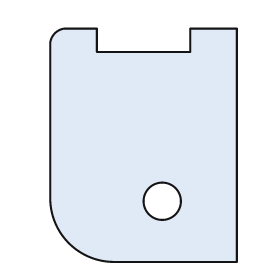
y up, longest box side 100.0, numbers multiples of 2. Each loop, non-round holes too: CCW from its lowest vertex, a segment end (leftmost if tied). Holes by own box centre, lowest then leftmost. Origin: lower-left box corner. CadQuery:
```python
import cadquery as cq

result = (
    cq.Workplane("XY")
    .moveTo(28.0, 0.0)
    .lineTo(80.0, 0.0)
    .lineTo(80.0, 100.0)
    .lineTo(60.0, 100.0)
    .lineTo(60.0, 90.0)
    .lineTo(20.0, 90.0)
    .lineTo(20.0, 100.0)
    .lineTo(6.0, 100.0)
    .threePointArc((2.0, 98.0), (0.0, 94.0))
    .lineTo(0.0, 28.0)
    .threePointArc((8.0, 8.0), (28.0, 0.0))
    .close()
    .moveTo(48.0, 26.0)
    .circle(8.0)
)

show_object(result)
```